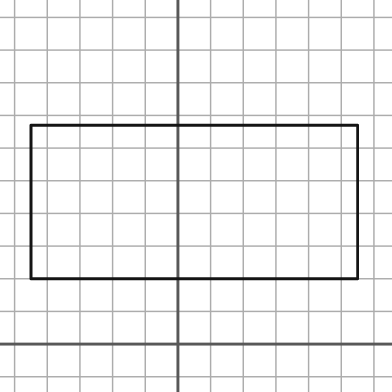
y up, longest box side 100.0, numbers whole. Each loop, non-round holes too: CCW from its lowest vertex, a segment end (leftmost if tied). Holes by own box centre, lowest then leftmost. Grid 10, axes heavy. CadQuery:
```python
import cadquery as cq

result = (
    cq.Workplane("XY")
    .moveTo(-45.0, 20.0)
    .lineTo(55.0, 20.0)
    .lineTo(55.0, 67.0)
    .lineTo(-45.0, 67.0)
    .close()
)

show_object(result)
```